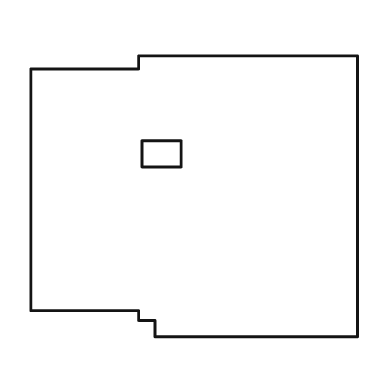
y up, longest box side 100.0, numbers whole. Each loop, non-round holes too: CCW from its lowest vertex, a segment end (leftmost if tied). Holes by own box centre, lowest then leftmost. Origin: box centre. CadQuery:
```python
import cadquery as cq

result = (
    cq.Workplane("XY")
    .moveTo(-12.0, -43.0)
    .lineTo(50.0, -43.0)
    .lineTo(50.0, 43.0)
    .lineTo(-17.0, 43.0)
    .lineTo(-17.0, 39.0)
    .lineTo(-50.0, 39.0)
    .lineTo(-50.0, -35.0)
    .lineTo(-17.0, -35.0)
    .lineTo(-17.0, -38.0)
    .lineTo(-12.0, -38.0)
    .close()
    .moveTo(-16.0, 9.0)
    .lineTo(-4.0, 9.0)
    .lineTo(-4.0, 17.0)
    .lineTo(-16.0, 17.0)
    .close()
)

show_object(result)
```